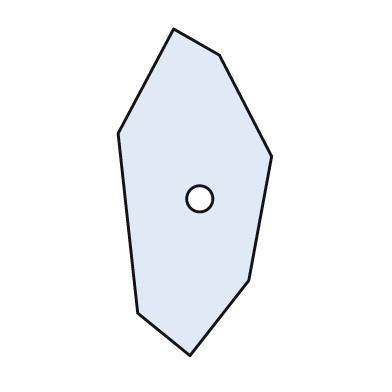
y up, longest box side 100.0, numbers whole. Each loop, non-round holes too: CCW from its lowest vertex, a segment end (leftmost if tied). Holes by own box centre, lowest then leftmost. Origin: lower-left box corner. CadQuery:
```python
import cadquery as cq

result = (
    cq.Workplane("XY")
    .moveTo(22.0, 0.0)
    .lineTo(40.0, 23.0)
    .lineTo(47.0, 61.0)
    .lineTo(31.0, 92.0)
    .lineTo(17.0, 100.0)
    .lineTo(0.0, 68.0)
    .lineTo(6.0, 13.0)
    .close()
    .moveTo(25.0, 48.0)
    .circle(4.0)
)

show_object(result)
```